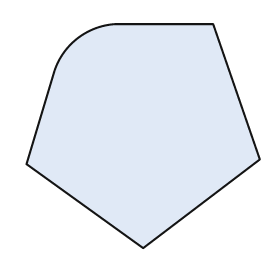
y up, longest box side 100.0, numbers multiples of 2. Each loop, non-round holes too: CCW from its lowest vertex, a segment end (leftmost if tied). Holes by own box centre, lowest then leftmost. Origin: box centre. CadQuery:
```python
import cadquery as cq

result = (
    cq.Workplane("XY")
    .moveTo(0.0, -48.0)
    .lineTo(50.0, -10.0)
    .lineTo(30.0, 48.0)
    .lineTo(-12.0, 48.0)
    .threePointArc((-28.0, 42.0), (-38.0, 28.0))
    .lineTo(-50.0, -12.0)
    .close()
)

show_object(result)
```